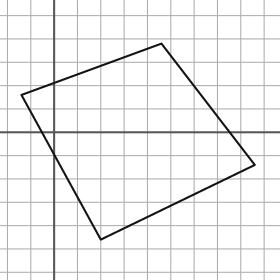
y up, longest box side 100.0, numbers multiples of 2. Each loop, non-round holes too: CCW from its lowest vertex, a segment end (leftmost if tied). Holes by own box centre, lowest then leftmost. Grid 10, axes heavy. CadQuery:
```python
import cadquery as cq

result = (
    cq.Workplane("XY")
    .moveTo(20.0, -46.0)
    .lineTo(86.0, -14.0)
    .lineTo(46.0, 38.0)
    .lineTo(-14.0, 16.0)
    .close()
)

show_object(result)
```